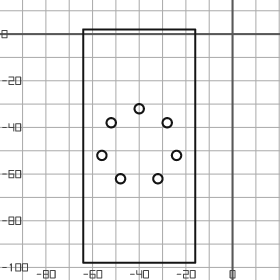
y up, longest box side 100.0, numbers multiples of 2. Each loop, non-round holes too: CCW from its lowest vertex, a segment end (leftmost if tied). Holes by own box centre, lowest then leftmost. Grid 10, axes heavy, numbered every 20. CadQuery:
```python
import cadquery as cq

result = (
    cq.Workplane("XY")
    .moveTo(-64.0, -98.0)
    .lineTo(-16.0, -98.0)
    .lineTo(-16.0, 2.0)
    .lineTo(-64.0, 2.0)
    .close()
    .moveTo(-48.0, -62.0)
    .circle(2.0)
    .moveTo(-32.0, -62.0)
    .circle(2.0)
    .moveTo(-56.0, -52.0)
    .circle(2.0)
    .moveTo(-24.0, -52.0)
    .circle(2.0)
    .moveTo(-52.0, -38.0)
    .circle(2.0)
    .moveTo(-28.0, -38.0)
    .circle(2.0)
    .moveTo(-40.0, -32.0)
    .circle(2.0)
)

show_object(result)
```